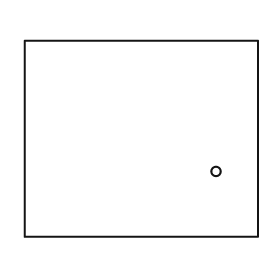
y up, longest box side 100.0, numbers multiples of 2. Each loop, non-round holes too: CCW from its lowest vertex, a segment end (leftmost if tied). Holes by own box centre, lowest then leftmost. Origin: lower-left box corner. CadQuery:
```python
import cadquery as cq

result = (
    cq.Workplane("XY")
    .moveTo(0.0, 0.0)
    .lineTo(100.0, 0.0)
    .lineTo(100.0, 84.0)
    .lineTo(0.0, 84.0)
    .close()
    .moveTo(82.0, 28.0)
    .circle(2.0)
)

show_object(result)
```